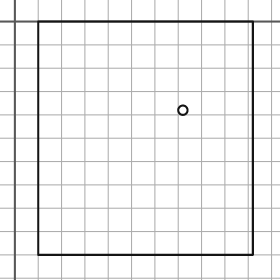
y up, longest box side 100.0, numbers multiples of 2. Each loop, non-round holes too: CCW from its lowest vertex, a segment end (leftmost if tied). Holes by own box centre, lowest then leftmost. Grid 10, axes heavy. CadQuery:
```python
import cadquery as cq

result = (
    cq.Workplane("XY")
    .moveTo(10.0, -100.0)
    .lineTo(102.0, -100.0)
    .lineTo(102.0, 0.0)
    .lineTo(10.0, 0.0)
    .close()
    .moveTo(72.0, -38.0)
    .circle(2.0)
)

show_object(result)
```